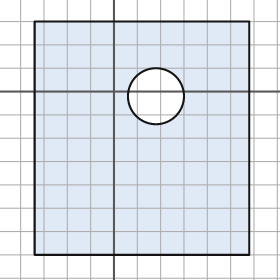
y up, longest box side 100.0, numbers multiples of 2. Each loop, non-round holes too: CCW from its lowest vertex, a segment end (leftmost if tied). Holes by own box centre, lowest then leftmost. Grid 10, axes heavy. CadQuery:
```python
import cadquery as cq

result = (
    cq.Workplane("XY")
    .moveTo(-34.0, -70.0)
    .lineTo(58.0, -70.0)
    .lineTo(58.0, 30.0)
    .lineTo(-34.0, 30.0)
    .close()
    .moveTo(18.0, -2.0)
    .circle(12.0)
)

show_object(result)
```